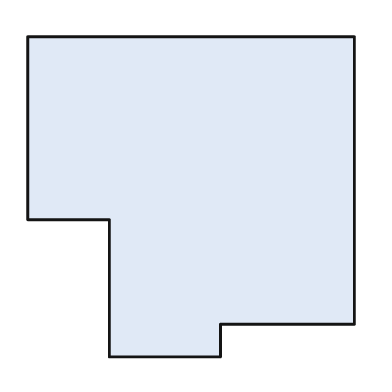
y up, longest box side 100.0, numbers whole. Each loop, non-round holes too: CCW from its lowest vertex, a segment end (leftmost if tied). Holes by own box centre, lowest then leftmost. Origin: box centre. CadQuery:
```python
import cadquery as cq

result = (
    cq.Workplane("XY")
    .moveTo(-25.0, -49.0)
    .lineTo(9.0, -49.0)
    .lineTo(9.0, -39.0)
    .lineTo(50.0, -39.0)
    .lineTo(50.0, 49.0)
    .lineTo(-50.0, 49.0)
    .lineTo(-50.0, -7.0)
    .lineTo(-25.0, -7.0)
    .close()
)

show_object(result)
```